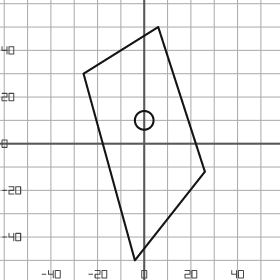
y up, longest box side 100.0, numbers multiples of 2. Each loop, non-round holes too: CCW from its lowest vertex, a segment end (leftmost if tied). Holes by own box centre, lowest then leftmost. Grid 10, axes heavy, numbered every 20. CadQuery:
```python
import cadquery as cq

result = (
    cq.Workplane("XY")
    .moveTo(-4.0, -50.0)
    .lineTo(26.0, -12.0)
    .lineTo(6.0, 50.0)
    .lineTo(-26.0, 30.0)
    .close()
    .moveTo(0.0, 10.0)
    .circle(4.0)
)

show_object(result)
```